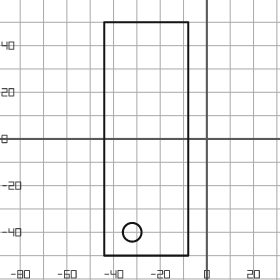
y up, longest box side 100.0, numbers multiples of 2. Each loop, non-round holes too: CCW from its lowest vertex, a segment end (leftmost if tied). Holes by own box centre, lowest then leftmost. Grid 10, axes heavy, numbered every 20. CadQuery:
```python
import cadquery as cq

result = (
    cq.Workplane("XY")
    .moveTo(-44.0, -50.0)
    .lineTo(-8.0, -50.0)
    .lineTo(-8.0, 50.0)
    .lineTo(-44.0, 50.0)
    .close()
    .moveTo(-32.0, -40.0)
    .circle(4.0)
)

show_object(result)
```